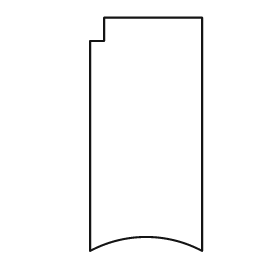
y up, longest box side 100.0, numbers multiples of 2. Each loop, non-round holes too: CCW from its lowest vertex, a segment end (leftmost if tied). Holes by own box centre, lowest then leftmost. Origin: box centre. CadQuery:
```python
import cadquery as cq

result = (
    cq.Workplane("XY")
    .moveTo(-24.0, -50.0)
    .threePointArc((0.0, -44.0), (24.0, -50.0))
    .lineTo(24.0, 50.0)
    .lineTo(-18.0, 50.0)
    .lineTo(-18.0, 40.0)
    .lineTo(-24.0, 40.0)
    .close()
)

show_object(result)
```